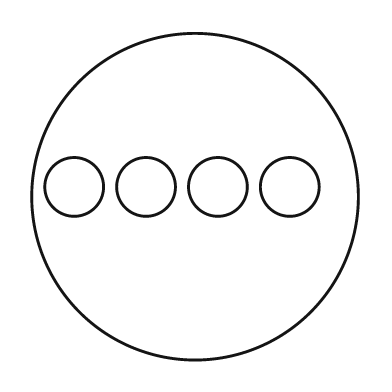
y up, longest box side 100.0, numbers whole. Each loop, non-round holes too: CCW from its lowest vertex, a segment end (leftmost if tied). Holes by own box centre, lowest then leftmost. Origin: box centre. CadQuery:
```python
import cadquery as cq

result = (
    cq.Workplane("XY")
    .moveTo(0.0, 0.0)
    .circle(50.0)
    .moveTo(-37.0, 3.0)
    .circle(9.0)
    .moveTo(-15.0, 3.0)
    .circle(9.0)
    .moveTo(7.0, 3.0)
    .circle(9.0)
    .moveTo(29.0, 3.0)
    .circle(9.0)
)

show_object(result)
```